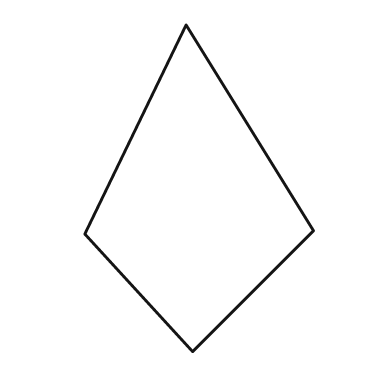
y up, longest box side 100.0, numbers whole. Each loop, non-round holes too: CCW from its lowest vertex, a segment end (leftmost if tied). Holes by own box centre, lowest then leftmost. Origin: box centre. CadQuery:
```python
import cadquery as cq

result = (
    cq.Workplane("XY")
    .moveTo(-2.0, -50.0)
    .lineTo(35.0, -13.0)
    .lineTo(-4.0, 50.0)
    .lineTo(-35.0, -14.0)
    .close()
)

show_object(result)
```